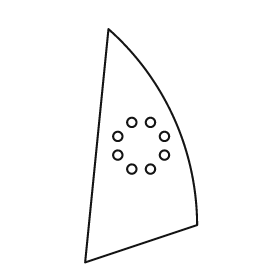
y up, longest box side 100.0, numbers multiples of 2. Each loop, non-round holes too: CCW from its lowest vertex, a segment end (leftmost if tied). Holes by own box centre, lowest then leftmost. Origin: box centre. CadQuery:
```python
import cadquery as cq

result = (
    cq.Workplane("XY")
    .moveTo(-24.0, -50.0)
    .lineTo(24.0, -34.0)
    .threePointArc((14.0, 12.0), (-14.0, 50.0))
    .close()
    .moveTo(-4.0, -10.0)
    .circle(2.0)
    .moveTo(4.0, -10.0)
    .circle(2.0)
    .moveTo(-10.0, -4.0)
    .circle(2.0)
    .moveTo(10.0, -4.0)
    .circle(2.0)
    .moveTo(-10.0, 4.0)
    .circle(2.0)
    .moveTo(10.0, 4.0)
    .circle(2.0)
    .moveTo(-4.0, 10.0)
    .circle(2.0)
    .moveTo(4.0, 10.0)
    .circle(2.0)
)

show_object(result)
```